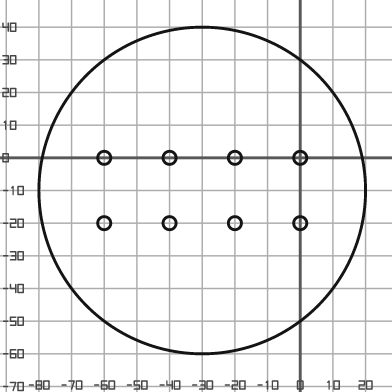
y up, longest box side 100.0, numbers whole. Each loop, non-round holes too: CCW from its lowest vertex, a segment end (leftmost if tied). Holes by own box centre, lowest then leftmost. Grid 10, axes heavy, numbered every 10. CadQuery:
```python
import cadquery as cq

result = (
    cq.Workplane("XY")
    .moveTo(-30.0, -10.0)
    .circle(50.0)
    .moveTo(-60.0, -20.0)
    .circle(2.0)
    .moveTo(-40.0, -20.0)
    .circle(2.0)
    .moveTo(-20.0, -20.0)
    .circle(2.0)
    .moveTo(0.0, -20.0)
    .circle(2.0)
    .moveTo(-60.0, 0.0)
    .circle(2.0)
    .moveTo(-40.0, 0.0)
    .circle(2.0)
    .moveTo(-20.0, 0.0)
    .circle(2.0)
    .moveTo(0.0, 0.0)
    .circle(2.0)
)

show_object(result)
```